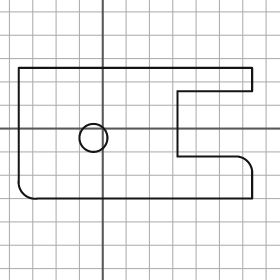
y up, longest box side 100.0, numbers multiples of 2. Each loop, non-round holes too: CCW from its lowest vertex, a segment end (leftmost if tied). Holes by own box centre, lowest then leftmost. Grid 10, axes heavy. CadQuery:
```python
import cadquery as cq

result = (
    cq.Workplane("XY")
    .moveTo(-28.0, -30.0)
    .lineTo(64.0, -30.0)
    .lineTo(64.0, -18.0)
    .threePointArc((62.0, -14.0), (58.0, -12.0))
    .lineTo(32.0, -12.0)
    .lineTo(32.0, 16.0)
    .lineTo(64.0, 16.0)
    .lineTo(64.0, 26.0)
    .lineTo(-36.0, 26.0)
    .lineTo(-36.0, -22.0)
    .threePointArc((-34.0, -28.0), (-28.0, -30.0))
    .close()
    .moveTo(-4.0, -4.0)
    .circle(6.0)
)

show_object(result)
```